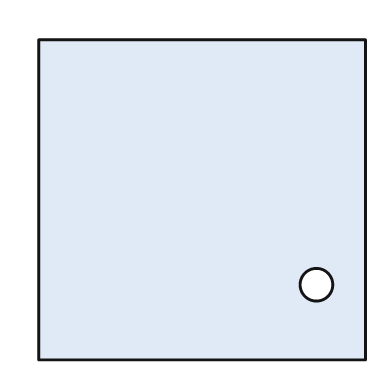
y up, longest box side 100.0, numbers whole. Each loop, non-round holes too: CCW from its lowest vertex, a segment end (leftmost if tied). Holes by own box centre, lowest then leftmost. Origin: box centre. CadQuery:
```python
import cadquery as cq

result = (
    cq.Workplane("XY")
    .moveTo(-50.0, -49.0)
    .lineTo(50.0, -49.0)
    .lineTo(50.0, 49.0)
    .lineTo(-50.0, 49.0)
    .close()
    .moveTo(35.0, -26.0)
    .circle(5.0)
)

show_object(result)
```